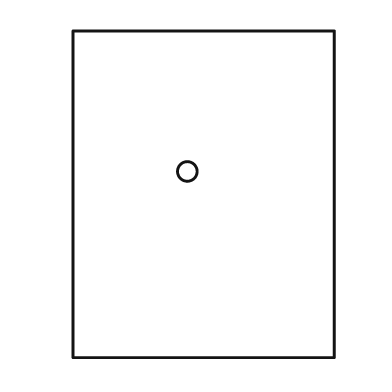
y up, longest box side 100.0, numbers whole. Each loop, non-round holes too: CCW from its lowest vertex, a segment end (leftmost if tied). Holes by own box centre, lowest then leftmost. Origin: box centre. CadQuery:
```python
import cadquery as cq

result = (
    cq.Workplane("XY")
    .moveTo(-40.0, -50.0)
    .lineTo(40.0, -50.0)
    .lineTo(40.0, 50.0)
    .lineTo(-40.0, 50.0)
    .close()
    .moveTo(-5.0, 7.0)
    .circle(3.0)
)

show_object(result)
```